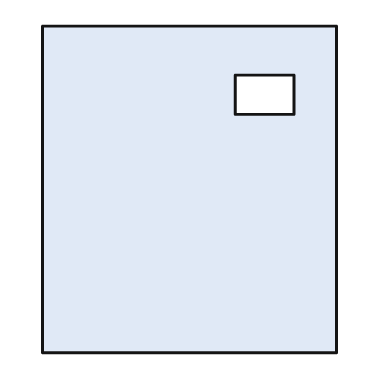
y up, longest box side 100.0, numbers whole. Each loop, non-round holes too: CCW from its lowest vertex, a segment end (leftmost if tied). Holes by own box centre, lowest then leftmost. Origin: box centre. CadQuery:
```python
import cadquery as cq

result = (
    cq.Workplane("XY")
    .moveTo(-45.0, -50.0)
    .lineTo(45.0, -50.0)
    .lineTo(45.0, 50.0)
    .lineTo(-45.0, 50.0)
    .close()
    .moveTo(14.0, 23.0)
    .lineTo(32.0, 23.0)
    .lineTo(32.0, 35.0)
    .lineTo(14.0, 35.0)
    .close()
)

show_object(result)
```